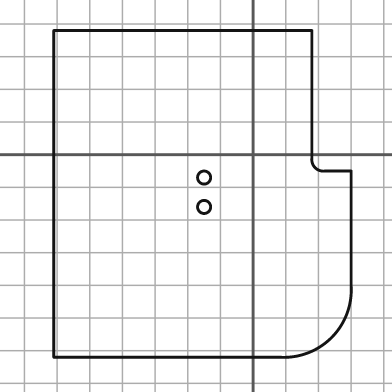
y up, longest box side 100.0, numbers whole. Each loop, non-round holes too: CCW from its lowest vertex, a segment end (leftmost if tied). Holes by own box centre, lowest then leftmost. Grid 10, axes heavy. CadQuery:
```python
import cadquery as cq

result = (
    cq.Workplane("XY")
    .moveTo(-61.0, -62.0)
    .lineTo(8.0, -62.0)
    .threePointArc((24.0, -56.0), (30.0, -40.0))
    .lineTo(30.0, -5.0)
    .lineTo(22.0, -5.0)
    .threePointArc((19.0, -4.0), (18.0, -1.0))
    .lineTo(18.0, 38.0)
    .lineTo(-61.0, 38.0)
    .close()
    .moveTo(-15.0, -16.0)
    .circle(2.0)
    .moveTo(-15.0, -7.0)
    .circle(2.0)
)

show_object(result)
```